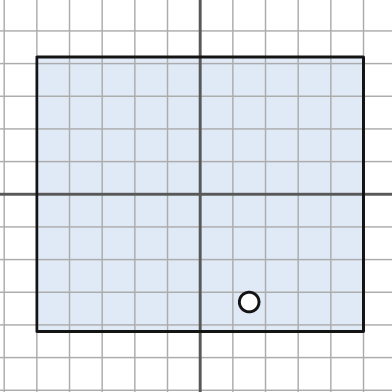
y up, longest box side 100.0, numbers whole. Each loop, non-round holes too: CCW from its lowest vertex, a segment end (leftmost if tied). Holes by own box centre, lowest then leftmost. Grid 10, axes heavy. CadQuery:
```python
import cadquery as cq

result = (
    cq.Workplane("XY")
    .moveTo(-50.0, -42.0)
    .lineTo(50.0, -42.0)
    .lineTo(50.0, 42.0)
    .lineTo(-50.0, 42.0)
    .close()
    .moveTo(15.0, -33.0)
    .circle(3.0)
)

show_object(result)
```